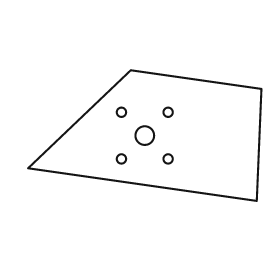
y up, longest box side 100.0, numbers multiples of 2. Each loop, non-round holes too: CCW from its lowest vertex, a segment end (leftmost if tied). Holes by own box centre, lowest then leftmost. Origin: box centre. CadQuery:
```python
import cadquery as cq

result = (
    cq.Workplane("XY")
    .moveTo(48.0, -28.0)
    .lineTo(50.0, 20.0)
    .lineTo(-6.0, 28.0)
    .lineTo(-50.0, -14.0)
    .close()
    .moveTo(-10.0, -10.0)
    .circle(2.0)
    .moveTo(10.0, -10.0)
    .circle(2.0)
    .moveTo(0.0, 0.0)
    .circle(4.0)
    .moveTo(-10.0, 10.0)
    .circle(2.0)
    .moveTo(10.0, 10.0)
    .circle(2.0)
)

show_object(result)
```